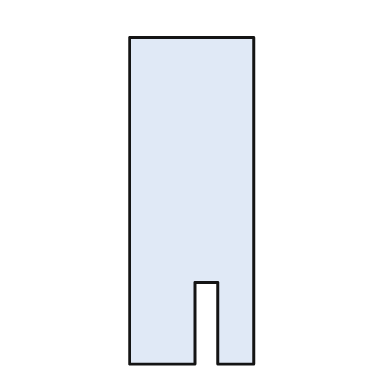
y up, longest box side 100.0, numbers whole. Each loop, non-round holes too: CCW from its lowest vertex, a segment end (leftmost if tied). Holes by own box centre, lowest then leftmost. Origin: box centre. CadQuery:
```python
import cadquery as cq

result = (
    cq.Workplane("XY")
    .moveTo(-19.0, -50.0)
    .lineTo(1.0, -50.0)
    .lineTo(1.0, -25.0)
    .lineTo(8.0, -25.0)
    .lineTo(8.0, -50.0)
    .lineTo(19.0, -50.0)
    .lineTo(19.0, 50.0)
    .lineTo(-19.0, 50.0)
    .close()
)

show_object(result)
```